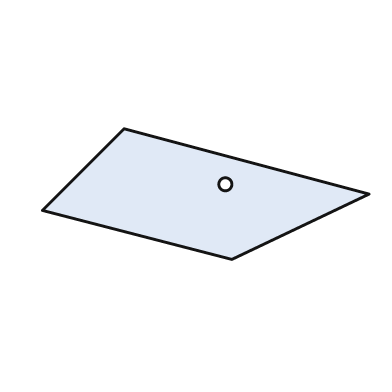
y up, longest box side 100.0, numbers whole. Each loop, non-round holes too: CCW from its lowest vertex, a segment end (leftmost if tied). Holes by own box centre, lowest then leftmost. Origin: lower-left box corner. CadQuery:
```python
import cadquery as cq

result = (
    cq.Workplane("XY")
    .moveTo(58.0, 0.0)
    .lineTo(100.0, 20.0)
    .lineTo(25.0, 40.0)
    .lineTo(0.0, 15.0)
    .close()
    .moveTo(56.0, 23.0)
    .circle(2.0)
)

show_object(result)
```